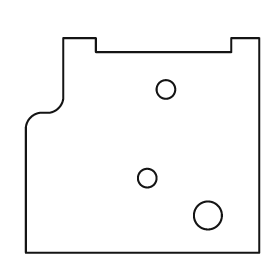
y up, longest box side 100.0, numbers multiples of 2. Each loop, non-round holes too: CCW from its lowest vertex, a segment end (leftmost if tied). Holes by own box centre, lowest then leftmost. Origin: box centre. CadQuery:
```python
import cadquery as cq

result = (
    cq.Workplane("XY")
    .moveTo(-50.0, -46.0)
    .lineTo(50.0, -46.0)
    .lineTo(50.0, 46.0)
    .lineTo(38.0, 46.0)
    .lineTo(38.0, 40.0)
    .lineTo(-20.0, 40.0)
    .lineTo(-20.0, 46.0)
    .lineTo(-34.0, 46.0)
    .lineTo(-34.0, 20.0)
    .threePointArc((-36.0, 16.0), (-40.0, 14.0))
    .lineTo(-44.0, 14.0)
    .threePointArc((-48.0, 12.0), (-50.0, 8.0))
    .close()
    .moveTo(28.0, -30.0)
    .circle(6.0)
    .moveTo(2.0, -14.0)
    .circle(4.0)
    .moveTo(10.0, 24.0)
    .circle(4.0)
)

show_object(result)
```